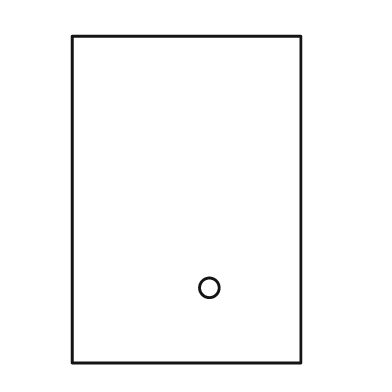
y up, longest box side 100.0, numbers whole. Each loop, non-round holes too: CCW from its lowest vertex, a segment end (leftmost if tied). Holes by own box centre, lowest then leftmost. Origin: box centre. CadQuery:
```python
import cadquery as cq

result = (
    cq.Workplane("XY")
    .moveTo(-35.0, -50.0)
    .lineTo(35.0, -50.0)
    .lineTo(35.0, 50.0)
    .lineTo(-35.0, 50.0)
    .close()
    .moveTo(7.0, -27.0)
    .circle(3.0)
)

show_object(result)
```